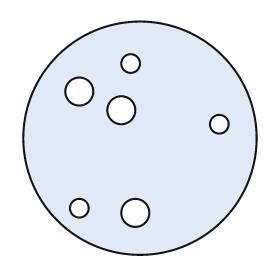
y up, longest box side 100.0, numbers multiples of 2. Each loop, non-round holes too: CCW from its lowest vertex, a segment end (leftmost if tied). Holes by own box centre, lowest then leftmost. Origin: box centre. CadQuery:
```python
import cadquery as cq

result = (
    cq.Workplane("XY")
    .moveTo(0.0, 0.0)
    .circle(50.0)
    .moveTo(-2.0, -32.0)
    .circle(6.0)
    .moveTo(-26.0, -30.0)
    .circle(4.0)
    .moveTo(34.0, 6.0)
    .circle(4.0)
    .moveTo(-8.0, 12.0)
    .circle(6.0)
    .moveTo(-26.0, 20.0)
    .circle(6.0)
    .moveTo(-4.0, 32.0)
    .circle(4.0)
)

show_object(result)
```